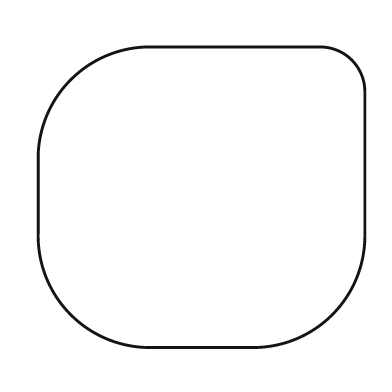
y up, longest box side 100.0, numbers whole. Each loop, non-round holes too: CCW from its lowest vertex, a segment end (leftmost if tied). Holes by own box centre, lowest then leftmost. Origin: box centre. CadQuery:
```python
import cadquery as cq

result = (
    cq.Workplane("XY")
    .moveTo(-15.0, -46.0)
    .lineTo(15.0, -46.0)
    .threePointArc((40.0, -36.0), (50.0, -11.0))
    .lineTo(50.0, 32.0)
    .threePointArc((46.0, 42.0), (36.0, 46.0))
    .lineTo(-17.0, 46.0)
    .threePointArc((-40.0, 36.0), (-50.0, 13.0))
    .lineTo(-50.0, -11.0)
    .threePointArc((-40.0, -36.0), (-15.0, -46.0))
    .close()
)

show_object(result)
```